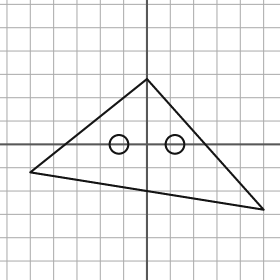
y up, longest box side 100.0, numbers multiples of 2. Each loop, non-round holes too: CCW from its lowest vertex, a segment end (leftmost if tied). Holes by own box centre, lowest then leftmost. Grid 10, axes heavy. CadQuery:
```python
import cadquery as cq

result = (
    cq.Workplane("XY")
    .moveTo(50.0, -28.0)
    .lineTo(0.0, 28.0)
    .lineTo(-50.0, -12.0)
    .close()
    .moveTo(-12.0, 0.0)
    .circle(4.0)
    .moveTo(12.0, 0.0)
    .circle(4.0)
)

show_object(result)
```